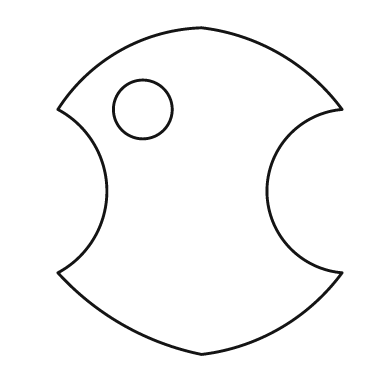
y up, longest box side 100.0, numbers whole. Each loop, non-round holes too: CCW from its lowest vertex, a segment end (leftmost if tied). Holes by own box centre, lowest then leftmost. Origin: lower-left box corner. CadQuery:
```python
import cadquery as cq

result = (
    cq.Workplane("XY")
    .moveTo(44.0, 0.0)
    .threePointArc((68.0, 8.0), (87.0, 25.0))
    .threePointArc((64.0, 50.0), (87.0, 75.0))
    .threePointArc((68.0, 92.0), (44.0, 100.0))
    .threePointArc((19.0, 93.0), (0.0, 75.0))
    .threePointArc((15.0, 50.0), (0.0, 25.0))
    .threePointArc((20.0, 9.0), (44.0, 0.0))
    .close()
    .moveTo(26.0, 75.0)
    .circle(9.0)
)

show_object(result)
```